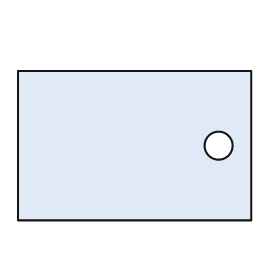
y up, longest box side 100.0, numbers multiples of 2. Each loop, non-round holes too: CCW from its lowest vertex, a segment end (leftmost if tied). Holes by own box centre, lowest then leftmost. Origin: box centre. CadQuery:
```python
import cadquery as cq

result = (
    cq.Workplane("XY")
    .moveTo(-50.0, -32.0)
    .lineTo(50.0, -32.0)
    .lineTo(50.0, 32.0)
    .lineTo(-50.0, 32.0)
    .close()
    .moveTo(36.0, 0.0)
    .circle(6.0)
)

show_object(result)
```